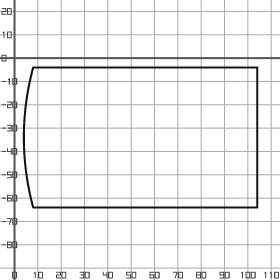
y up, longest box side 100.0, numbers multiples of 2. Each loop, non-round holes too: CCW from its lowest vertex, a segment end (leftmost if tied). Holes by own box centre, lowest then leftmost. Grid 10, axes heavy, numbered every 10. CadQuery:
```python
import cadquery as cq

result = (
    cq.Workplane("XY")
    .moveTo(8.0, -64.0)
    .lineTo(104.0, -64.0)
    .lineTo(104.0, -4.0)
    .lineTo(8.0, -4.0)
    .threePointArc((4.0, -34.0), (8.0, -64.0))
    .close()
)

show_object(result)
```